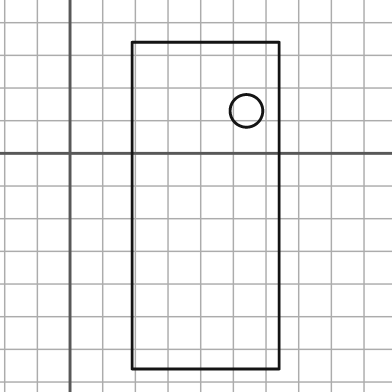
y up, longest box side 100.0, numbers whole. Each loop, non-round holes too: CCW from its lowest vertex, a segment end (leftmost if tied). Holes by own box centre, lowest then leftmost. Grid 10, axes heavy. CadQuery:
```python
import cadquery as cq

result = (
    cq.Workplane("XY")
    .moveTo(19.0, -66.0)
    .lineTo(64.0, -66.0)
    .lineTo(64.0, 34.0)
    .lineTo(19.0, 34.0)
    .close()
    .moveTo(54.0, 13.0)
    .circle(5.0)
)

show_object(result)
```